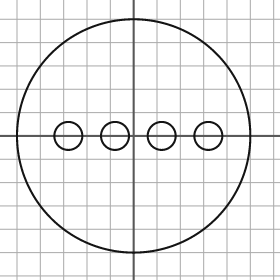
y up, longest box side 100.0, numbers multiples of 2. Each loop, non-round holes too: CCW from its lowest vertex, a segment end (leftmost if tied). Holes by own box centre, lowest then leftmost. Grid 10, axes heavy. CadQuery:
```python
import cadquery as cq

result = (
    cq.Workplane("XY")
    .moveTo(0.0, 0.0)
    .circle(50.0)
    .moveTo(-28.0, 0.0)
    .circle(6.0)
    .moveTo(-8.0, 0.0)
    .circle(6.0)
    .moveTo(12.0, 0.0)
    .circle(6.0)
    .moveTo(32.0, 0.0)
    .circle(6.0)
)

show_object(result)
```